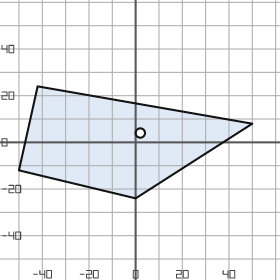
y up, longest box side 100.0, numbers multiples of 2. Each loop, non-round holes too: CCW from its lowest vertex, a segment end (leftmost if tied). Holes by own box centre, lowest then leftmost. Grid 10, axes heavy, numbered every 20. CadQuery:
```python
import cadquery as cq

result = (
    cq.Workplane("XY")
    .moveTo(0.0, -24.0)
    .lineTo(50.0, 8.0)
    .lineTo(-42.0, 24.0)
    .lineTo(-50.0, -12.0)
    .close()
    .moveTo(2.0, 4.0)
    .circle(2.0)
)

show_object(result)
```